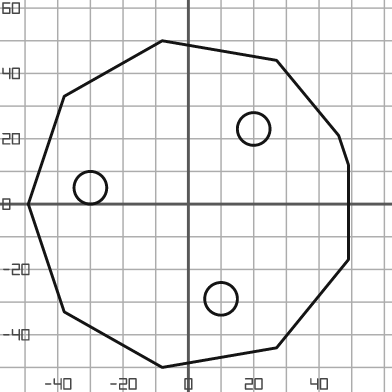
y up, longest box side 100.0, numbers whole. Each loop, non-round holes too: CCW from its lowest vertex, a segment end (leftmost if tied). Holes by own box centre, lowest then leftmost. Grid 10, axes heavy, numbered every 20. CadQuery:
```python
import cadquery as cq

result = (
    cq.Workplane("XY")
    .moveTo(-8.0, -50.0)
    .lineTo(27.0, -44.0)
    .lineTo(49.0, -17.0)
    .lineTo(49.0, 12.0)
    .lineTo(46.0, 21.0)
    .lineTo(27.0, 44.0)
    .lineTo(-8.0, 50.0)
    .lineTo(-38.0, 33.0)
    .lineTo(-49.0, 0.0)
    .lineTo(-38.0, -33.0)
    .close()
    .moveTo(10.0, -29.0)
    .circle(5.0)
    .moveTo(-30.0, 5.0)
    .circle(5.0)
    .moveTo(20.0, 23.0)
    .circle(5.0)
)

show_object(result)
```